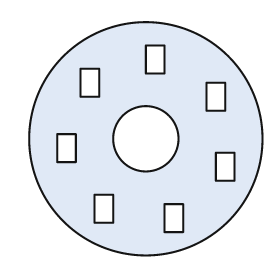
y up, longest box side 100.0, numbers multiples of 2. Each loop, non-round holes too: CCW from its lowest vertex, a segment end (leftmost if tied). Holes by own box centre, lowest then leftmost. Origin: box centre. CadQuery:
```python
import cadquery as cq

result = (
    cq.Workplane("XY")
    .moveTo(0.0, 0.0)
    .circle(50.0)
    .moveTo(8.0, -40.0)
    .lineTo(16.0, -40.0)
    .lineTo(16.0, -28.0)
    .lineTo(8.0, -28.0)
    .close()
    .moveTo(-22.0, -36.0)
    .lineTo(-14.0, -36.0)
    .lineTo(-14.0, -24.0)
    .lineTo(-22.0, -24.0)
    .close()
    .moveTo(30.0, -18.0)
    .lineTo(38.0, -18.0)
    .lineTo(38.0, -6.0)
    .lineTo(30.0, -6.0)
    .close()
    .moveTo(-38.0, -10.0)
    .lineTo(-30.0, -10.0)
    .lineTo(-30.0, 2.0)
    .lineTo(-38.0, 2.0)
    .close()
    .moveTo(0.0, 0.0)
    .circle(14.0)
    .moveTo(26.0, 12.0)
    .lineTo(34.0, 12.0)
    .lineTo(34.0, 24.0)
    .lineTo(26.0, 24.0)
    .close()
    .moveTo(-28.0, 18.0)
    .lineTo(-20.0, 18.0)
    .lineTo(-20.0, 30.0)
    .lineTo(-28.0, 30.0)
    .close()
    .moveTo(0.0, 28.0)
    .lineTo(8.0, 28.0)
    .lineTo(8.0, 40.0)
    .lineTo(0.0, 40.0)
    .close()
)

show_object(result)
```